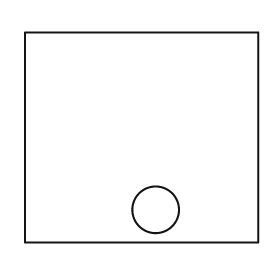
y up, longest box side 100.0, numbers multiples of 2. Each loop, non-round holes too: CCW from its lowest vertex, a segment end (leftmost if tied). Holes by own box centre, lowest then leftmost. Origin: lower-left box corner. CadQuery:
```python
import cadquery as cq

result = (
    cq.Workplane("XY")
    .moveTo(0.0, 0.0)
    .lineTo(100.0, 0.0)
    .lineTo(100.0, 90.0)
    .lineTo(0.0, 90.0)
    .close()
    .moveTo(56.0, 14.0)
    .circle(10.0)
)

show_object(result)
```